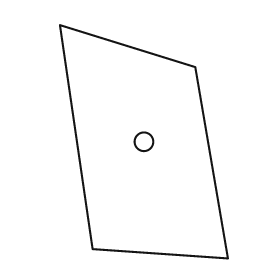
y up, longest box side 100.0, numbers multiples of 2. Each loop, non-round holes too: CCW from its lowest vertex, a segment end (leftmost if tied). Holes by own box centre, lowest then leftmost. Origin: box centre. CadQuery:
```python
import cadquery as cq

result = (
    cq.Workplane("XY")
    .moveTo(36.0, -50.0)
    .lineTo(22.0, 32.0)
    .lineTo(-36.0, 50.0)
    .lineTo(-22.0, -46.0)
    .close()
    .moveTo(0.0, 0.0)
    .circle(4.0)
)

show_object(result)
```